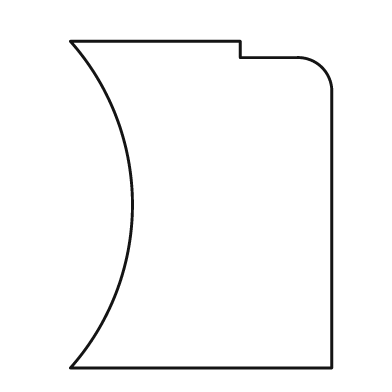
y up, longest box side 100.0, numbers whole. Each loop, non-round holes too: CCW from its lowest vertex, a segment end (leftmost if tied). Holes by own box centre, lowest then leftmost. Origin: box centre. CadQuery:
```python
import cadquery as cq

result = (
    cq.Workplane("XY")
    .moveTo(-40.0, -50.0)
    .lineTo(40.0, -50.0)
    .lineTo(40.0, 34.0)
    .threePointArc((37.0, 42.0), (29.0, 45.0))
    .lineTo(12.0, 45.0)
    .lineTo(12.0, 50.0)
    .lineTo(-40.0, 50.0)
    .threePointArc((-21.0, 0.0), (-40.0, -50.0))
    .close()
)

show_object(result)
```